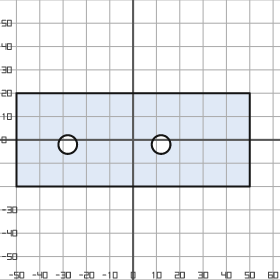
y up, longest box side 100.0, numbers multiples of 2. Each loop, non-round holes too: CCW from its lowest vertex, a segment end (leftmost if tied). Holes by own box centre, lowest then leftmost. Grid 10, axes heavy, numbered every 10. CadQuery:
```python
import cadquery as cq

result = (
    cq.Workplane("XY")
    .moveTo(-50.0, -20.0)
    .lineTo(50.0, -20.0)
    .lineTo(50.0, 20.0)
    .lineTo(-50.0, 20.0)
    .close()
    .moveTo(-28.0, -2.0)
    .circle(4.0)
    .moveTo(12.0, -2.0)
    .circle(4.0)
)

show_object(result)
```